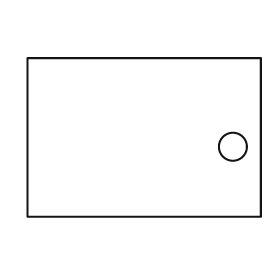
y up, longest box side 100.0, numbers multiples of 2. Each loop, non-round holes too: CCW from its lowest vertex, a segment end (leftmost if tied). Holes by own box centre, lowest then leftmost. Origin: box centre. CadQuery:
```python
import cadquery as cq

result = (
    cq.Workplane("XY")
    .moveTo(-50.0, -34.0)
    .lineTo(50.0, -34.0)
    .lineTo(50.0, 34.0)
    .lineTo(-50.0, 34.0)
    .close()
    .moveTo(38.0, -4.0)
    .circle(6.0)
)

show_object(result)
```